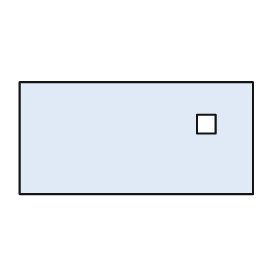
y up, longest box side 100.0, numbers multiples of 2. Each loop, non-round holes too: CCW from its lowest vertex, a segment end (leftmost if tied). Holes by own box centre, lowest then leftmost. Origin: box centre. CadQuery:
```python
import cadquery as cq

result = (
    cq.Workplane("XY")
    .moveTo(-50.0, -24.0)
    .lineTo(50.0, -24.0)
    .lineTo(50.0, 24.0)
    .lineTo(-50.0, 24.0)
    .close()
    .moveTo(26.0, 2.0)
    .lineTo(34.0, 2.0)
    .lineTo(34.0, 10.0)
    .lineTo(26.0, 10.0)
    .close()
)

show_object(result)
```